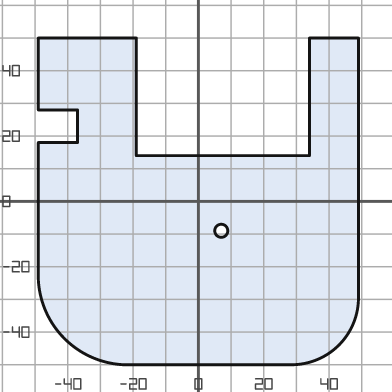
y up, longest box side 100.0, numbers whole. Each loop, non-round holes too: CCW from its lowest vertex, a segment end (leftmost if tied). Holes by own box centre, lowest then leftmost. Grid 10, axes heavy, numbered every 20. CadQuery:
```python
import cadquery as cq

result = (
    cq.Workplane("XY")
    .moveTo(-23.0, -50.0)
    .lineTo(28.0, -50.0)
    .threePointArc((43.0, -44.0), (49.0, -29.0))
    .lineTo(49.0, 50.0)
    .lineTo(34.0, 50.0)
    .lineTo(34.0, 14.0)
    .lineTo(-19.0, 14.0)
    .lineTo(-19.0, 50.0)
    .lineTo(-49.0, 50.0)
    .lineTo(-49.0, 28.0)
    .lineTo(-37.0, 28.0)
    .lineTo(-37.0, 18.0)
    .lineTo(-49.0, 18.0)
    .lineTo(-49.0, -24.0)
    .threePointArc((-41.0, -42.0), (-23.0, -50.0))
    .close()
    .moveTo(7.0, -9.0)
    .circle(2.0)
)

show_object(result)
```